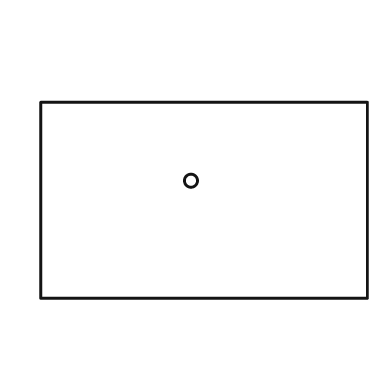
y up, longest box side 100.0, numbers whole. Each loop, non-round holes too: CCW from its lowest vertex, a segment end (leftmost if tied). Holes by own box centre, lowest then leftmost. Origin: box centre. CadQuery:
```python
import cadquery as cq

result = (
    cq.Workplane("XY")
    .moveTo(-50.0, -30.0)
    .lineTo(50.0, -30.0)
    .lineTo(50.0, 30.0)
    .lineTo(-50.0, 30.0)
    .close()
    .moveTo(-4.0, 6.0)
    .circle(2.0)
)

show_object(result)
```